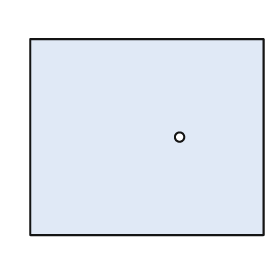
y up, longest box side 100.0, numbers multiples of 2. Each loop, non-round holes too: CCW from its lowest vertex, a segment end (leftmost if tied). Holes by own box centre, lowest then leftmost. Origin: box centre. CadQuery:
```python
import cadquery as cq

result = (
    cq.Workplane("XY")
    .moveTo(-50.0, -42.0)
    .lineTo(50.0, -42.0)
    .lineTo(50.0, 42.0)
    .lineTo(-50.0, 42.0)
    .close()
    .moveTo(14.0, 0.0)
    .circle(2.0)
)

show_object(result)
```